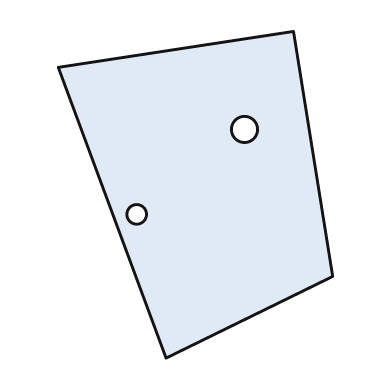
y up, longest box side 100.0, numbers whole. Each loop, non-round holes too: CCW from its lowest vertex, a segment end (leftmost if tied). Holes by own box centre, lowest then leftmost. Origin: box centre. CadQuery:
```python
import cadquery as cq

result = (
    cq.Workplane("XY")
    .moveTo(-9.0, -50.0)
    .lineTo(42.0, -25.0)
    .lineTo(30.0, 50.0)
    .lineTo(-42.0, 39.0)
    .close()
    .moveTo(-18.0, -6.0)
    .circle(3.0)
    .moveTo(15.0, 20.0)
    .circle(4.0)
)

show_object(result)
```